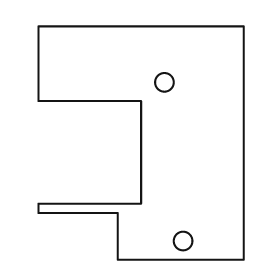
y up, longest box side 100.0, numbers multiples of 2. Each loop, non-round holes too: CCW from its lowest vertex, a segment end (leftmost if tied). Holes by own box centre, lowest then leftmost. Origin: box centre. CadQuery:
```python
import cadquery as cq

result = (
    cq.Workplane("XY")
    .moveTo(-10.0, -50.0)
    .lineTo(44.0, -50.0)
    .lineTo(44.0, 50.0)
    .lineTo(-44.0, 50.0)
    .lineTo(-44.0, 18.0)
    .lineTo(0.0, 18.0)
    .lineTo(0.0, -26.0)
    .lineTo(-44.0, -26.0)
    .lineTo(-44.0, -30.0)
    .lineTo(-10.0, -30.0)
    .close()
    .moveTo(18.0, -42.0)
    .circle(4.0)
    .moveTo(10.0, 26.0)
    .circle(4.0)
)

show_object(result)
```